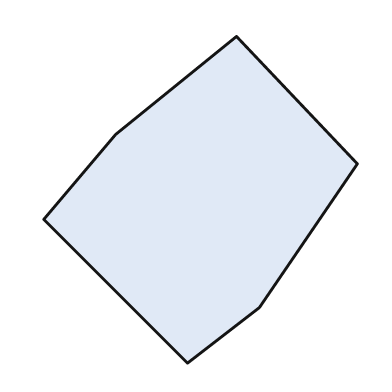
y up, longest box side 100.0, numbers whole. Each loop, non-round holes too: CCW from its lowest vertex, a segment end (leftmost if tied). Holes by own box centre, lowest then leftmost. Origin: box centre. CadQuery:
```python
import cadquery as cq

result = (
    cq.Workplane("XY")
    .moveTo(-4.0, -50.0)
    .lineTo(18.0, -33.0)
    .lineTo(48.0, 11.0)
    .lineTo(11.0, 50.0)
    .lineTo(-26.0, 20.0)
    .lineTo(-48.0, -6.0)
    .close()
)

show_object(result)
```